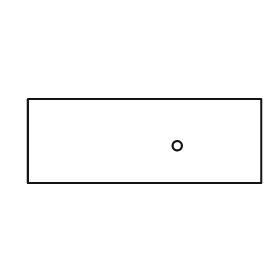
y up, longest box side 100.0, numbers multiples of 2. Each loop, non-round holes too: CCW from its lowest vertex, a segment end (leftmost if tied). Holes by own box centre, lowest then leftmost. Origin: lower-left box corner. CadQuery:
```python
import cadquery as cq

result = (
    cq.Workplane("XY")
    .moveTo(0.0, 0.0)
    .lineTo(100.0, 0.0)
    .lineTo(100.0, 36.0)
    .lineTo(0.0, 36.0)
    .close()
    .moveTo(64.0, 16.0)
    .circle(2.0)
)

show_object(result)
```